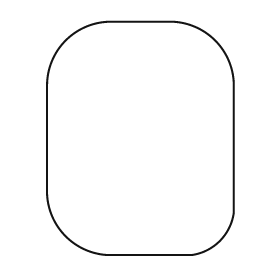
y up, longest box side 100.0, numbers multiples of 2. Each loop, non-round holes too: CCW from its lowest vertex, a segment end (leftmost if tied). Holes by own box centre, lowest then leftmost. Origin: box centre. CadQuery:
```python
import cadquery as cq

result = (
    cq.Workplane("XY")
    .moveTo(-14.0, -50.0)
    .lineTo(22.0, -50.0)
    .threePointArc((34.0, -44.0), (40.0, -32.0))
    .lineTo(40.0, 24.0)
    .threePointArc((32.0, 42.0), (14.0, 50.0))
    .lineTo(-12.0, 50.0)
    .threePointArc((-32.0, 42.0), (-40.0, 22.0))
    .lineTo(-40.0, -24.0)
    .threePointArc((-32.0, -42.0), (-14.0, -50.0))
    .close()
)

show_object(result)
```